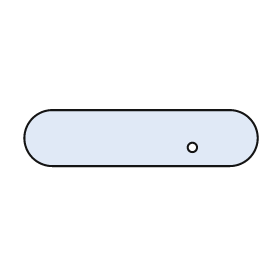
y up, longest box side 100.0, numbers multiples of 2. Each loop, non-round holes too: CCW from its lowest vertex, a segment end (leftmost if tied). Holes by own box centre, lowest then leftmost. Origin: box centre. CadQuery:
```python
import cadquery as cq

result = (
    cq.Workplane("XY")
    .moveTo(-38.0, -12.0)
    .lineTo(38.0, -12.0)
    .threePointArc((50.0, 0.0), (38.0, 12.0))
    .lineTo(-38.0, 12.0)
    .threePointArc((-50.0, 0.0), (-38.0, -12.0))
    .close()
    .moveTo(22.0, -4.0)
    .circle(2.0)
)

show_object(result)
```